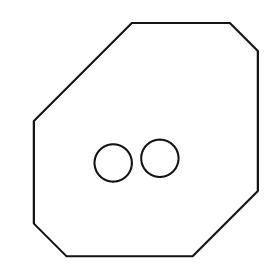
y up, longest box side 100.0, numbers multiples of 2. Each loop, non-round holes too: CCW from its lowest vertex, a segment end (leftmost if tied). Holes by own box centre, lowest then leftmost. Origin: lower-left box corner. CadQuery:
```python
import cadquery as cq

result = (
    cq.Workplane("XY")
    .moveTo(14.0, 0.0)
    .lineTo(68.0, 0.0)
    .lineTo(96.0, 28.0)
    .lineTo(96.0, 88.0)
    .lineTo(84.0, 100.0)
    .lineTo(42.0, 100.0)
    .lineTo(0.0, 58.0)
    .lineTo(0.0, 14.0)
    .close()
    .moveTo(34.0, 40.0)
    .circle(8.0)
    .moveTo(54.0, 42.0)
    .circle(8.0)
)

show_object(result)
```